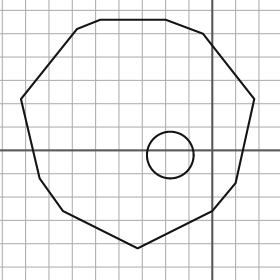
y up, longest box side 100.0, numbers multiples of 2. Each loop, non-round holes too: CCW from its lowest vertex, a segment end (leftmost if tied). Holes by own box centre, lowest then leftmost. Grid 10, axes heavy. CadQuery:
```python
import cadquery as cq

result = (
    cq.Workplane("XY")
    .moveTo(-32.0, -42.0)
    .lineTo(0.0, -26.0)
    .lineTo(10.0, -14.0)
    .lineTo(18.0, 22.0)
    .lineTo(-4.0, 50.0)
    .lineTo(-20.0, 56.0)
    .lineTo(-48.0, 56.0)
    .lineTo(-58.0, 52.0)
    .lineTo(-82.0, 22.0)
    .lineTo(-74.0, -12.0)
    .lineTo(-64.0, -26.0)
    .close()
    .moveTo(-18.0, -2.0)
    .circle(10.0)
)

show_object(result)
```